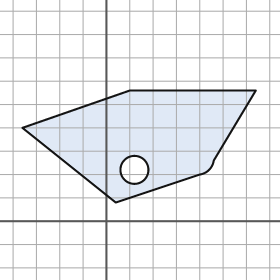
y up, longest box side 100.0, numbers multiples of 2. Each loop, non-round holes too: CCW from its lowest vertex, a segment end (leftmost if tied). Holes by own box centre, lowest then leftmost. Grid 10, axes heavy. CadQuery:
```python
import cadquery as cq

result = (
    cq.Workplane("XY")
    .moveTo(4.0, 8.0)
    .lineTo(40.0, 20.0)
    .threePointArc((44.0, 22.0), (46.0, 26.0))
    .lineTo(64.0, 56.0)
    .lineTo(10.0, 56.0)
    .lineTo(-36.0, 40.0)
    .close()
    .moveTo(12.0, 22.0)
    .circle(6.0)
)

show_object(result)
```